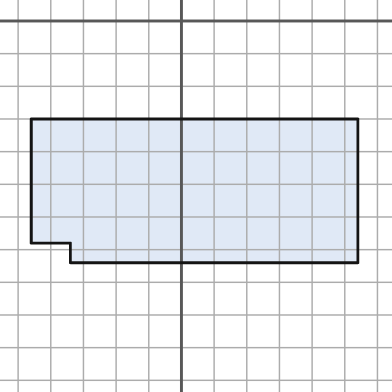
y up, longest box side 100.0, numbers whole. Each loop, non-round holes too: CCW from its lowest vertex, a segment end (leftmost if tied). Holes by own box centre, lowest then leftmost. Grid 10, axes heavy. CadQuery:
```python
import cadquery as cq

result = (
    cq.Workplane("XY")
    .moveTo(-34.0, -74.0)
    .lineTo(54.0, -74.0)
    .lineTo(54.0, -30.0)
    .lineTo(-46.0, -30.0)
    .lineTo(-46.0, -68.0)
    .lineTo(-34.0, -68.0)
    .close()
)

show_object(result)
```